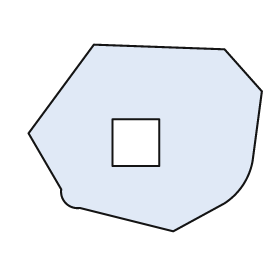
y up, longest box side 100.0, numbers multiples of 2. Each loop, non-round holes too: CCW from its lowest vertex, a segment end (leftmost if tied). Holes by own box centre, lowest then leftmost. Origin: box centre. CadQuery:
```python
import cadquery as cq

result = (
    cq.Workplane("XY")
    .moveTo(12.0, -40.0)
    .lineTo(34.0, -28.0)
    .threePointArc((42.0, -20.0), (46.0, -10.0))
    .lineTo(50.0, 20.0)
    .lineTo(34.0, 38.0)
    .lineTo(-22.0, 40.0)
    .lineTo(-50.0, 2.0)
    .lineTo(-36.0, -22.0)
    .threePointArc((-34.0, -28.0), (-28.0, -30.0))
    .close()
    .moveTo(-14.0, -12.0)
    .lineTo(6.0, -12.0)
    .lineTo(6.0, 8.0)
    .lineTo(-14.0, 8.0)
    .close()
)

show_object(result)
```